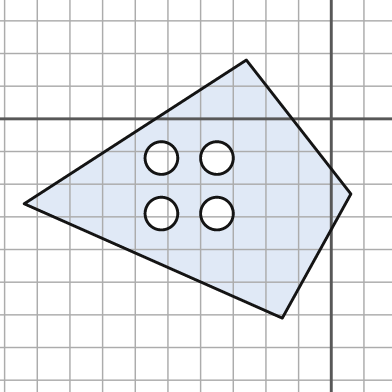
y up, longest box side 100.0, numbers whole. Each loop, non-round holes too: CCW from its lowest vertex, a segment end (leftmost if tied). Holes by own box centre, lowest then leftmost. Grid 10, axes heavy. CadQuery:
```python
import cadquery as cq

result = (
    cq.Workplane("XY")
    .moveTo(-15.0, -61.0)
    .lineTo(6.0, -23.0)
    .lineTo(-26.0, 18.0)
    .lineTo(-94.0, -26.0)
    .close()
    .moveTo(-52.0, -29.0)
    .circle(5.0)
    .moveTo(-35.0, -29.0)
    .circle(5.0)
    .moveTo(-52.0, -12.0)
    .circle(5.0)
    .moveTo(-35.0, -12.0)
    .circle(5.0)
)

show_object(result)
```